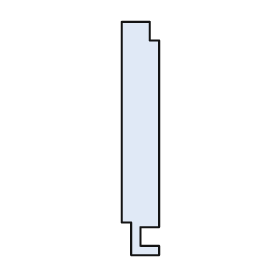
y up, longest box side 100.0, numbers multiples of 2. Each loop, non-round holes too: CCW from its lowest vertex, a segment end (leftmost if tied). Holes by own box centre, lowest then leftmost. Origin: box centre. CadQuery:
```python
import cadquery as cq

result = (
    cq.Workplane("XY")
    .moveTo(-4.0, -50.0)
    .lineTo(8.0, -50.0)
    .lineTo(8.0, -46.0)
    .lineTo(0.0, -46.0)
    .lineTo(0.0, -38.0)
    .lineTo(8.0, -38.0)
    .lineTo(8.0, 42.0)
    .lineTo(4.0, 42.0)
    .lineTo(4.0, 50.0)
    .lineTo(-8.0, 50.0)
    .lineTo(-8.0, -36.0)
    .lineTo(-4.0, -36.0)
    .close()
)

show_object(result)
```